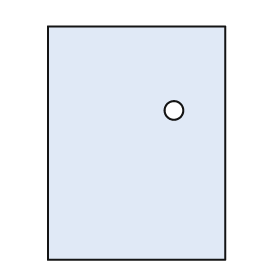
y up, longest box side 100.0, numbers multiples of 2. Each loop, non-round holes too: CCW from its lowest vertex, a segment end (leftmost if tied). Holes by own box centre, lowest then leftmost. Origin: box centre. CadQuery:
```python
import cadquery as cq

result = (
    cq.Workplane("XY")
    .moveTo(-38.0, -50.0)
    .lineTo(38.0, -50.0)
    .lineTo(38.0, 50.0)
    .lineTo(-38.0, 50.0)
    .close()
    .moveTo(16.0, 14.0)
    .circle(4.0)
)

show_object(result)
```